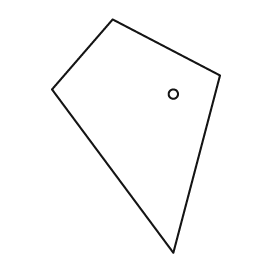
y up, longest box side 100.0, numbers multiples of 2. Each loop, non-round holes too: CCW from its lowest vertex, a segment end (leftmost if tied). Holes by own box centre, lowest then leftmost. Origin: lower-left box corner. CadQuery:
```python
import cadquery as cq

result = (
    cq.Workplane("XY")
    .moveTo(52.0, 0.0)
    .lineTo(72.0, 76.0)
    .lineTo(26.0, 100.0)
    .lineTo(0.0, 70.0)
    .close()
    .moveTo(52.0, 68.0)
    .circle(2.0)
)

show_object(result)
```